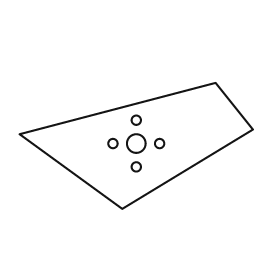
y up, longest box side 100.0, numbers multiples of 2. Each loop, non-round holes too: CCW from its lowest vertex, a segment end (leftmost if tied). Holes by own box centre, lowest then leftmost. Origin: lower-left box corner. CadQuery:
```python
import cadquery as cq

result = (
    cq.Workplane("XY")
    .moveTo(44.0, 0.0)
    .lineTo(100.0, 34.0)
    .lineTo(84.0, 54.0)
    .lineTo(0.0, 32.0)
    .close()
    .moveTo(50.0, 18.0)
    .circle(2.0)
    .moveTo(40.0, 28.0)
    .circle(2.0)
    .moveTo(50.0, 28.0)
    .circle(4.0)
    .moveTo(60.0, 28.0)
    .circle(2.0)
    .moveTo(50.0, 38.0)
    .circle(2.0)
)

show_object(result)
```